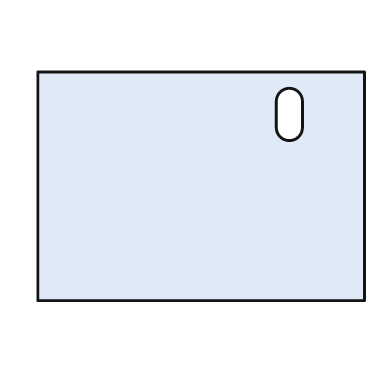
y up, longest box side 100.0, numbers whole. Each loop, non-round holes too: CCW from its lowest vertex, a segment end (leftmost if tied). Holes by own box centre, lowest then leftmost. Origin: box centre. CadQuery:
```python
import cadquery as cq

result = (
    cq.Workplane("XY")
    .moveTo(-50.0, -35.0)
    .lineTo(50.0, -35.0)
    .lineTo(50.0, 35.0)
    .lineTo(-50.0, 35.0)
    .close()
    .moveTo(23.0, 18.0)
    .threePointArc((27.0, 14.0), (31.0, 18.0))
    .lineTo(31.0, 26.0)
    .threePointArc((27.0, 30.0), (23.0, 26.0))
    .close()
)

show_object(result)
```